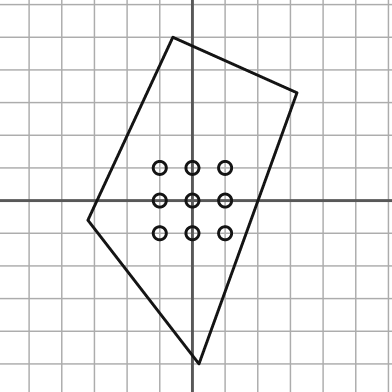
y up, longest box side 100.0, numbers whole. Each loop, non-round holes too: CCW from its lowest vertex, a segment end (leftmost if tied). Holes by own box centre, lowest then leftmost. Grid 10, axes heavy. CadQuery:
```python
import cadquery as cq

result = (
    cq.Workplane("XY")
    .moveTo(2.0, -50.0)
    .lineTo(32.0, 33.0)
    .lineTo(-6.0, 50.0)
    .lineTo(-32.0, -6.0)
    .close()
    .moveTo(-10.0, -10.0)
    .circle(2.0)
    .moveTo(0.0, -10.0)
    .circle(2.0)
    .moveTo(10.0, -10.0)
    .circle(2.0)
    .moveTo(-10.0, 0.0)
    .circle(2.0)
    .moveTo(0.0, 0.0)
    .circle(2.0)
    .moveTo(10.0, 0.0)
    .circle(2.0)
    .moveTo(-10.0, 10.0)
    .circle(2.0)
    .moveTo(0.0, 10.0)
    .circle(2.0)
    .moveTo(10.0, 10.0)
    .circle(2.0)
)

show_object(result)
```